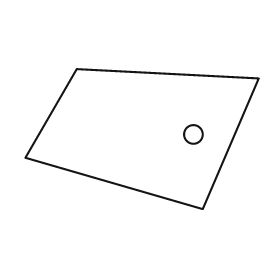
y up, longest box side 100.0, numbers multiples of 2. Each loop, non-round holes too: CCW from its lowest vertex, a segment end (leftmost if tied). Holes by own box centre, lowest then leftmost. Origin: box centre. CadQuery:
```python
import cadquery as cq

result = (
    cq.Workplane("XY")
    .moveTo(26.0, -30.0)
    .lineTo(50.0, 26.0)
    .lineTo(-28.0, 30.0)
    .lineTo(-50.0, -8.0)
    .close()
    .moveTo(22.0, 2.0)
    .circle(4.0)
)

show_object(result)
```